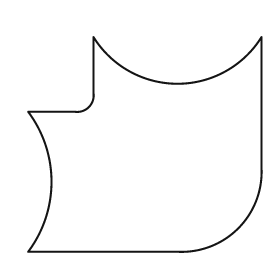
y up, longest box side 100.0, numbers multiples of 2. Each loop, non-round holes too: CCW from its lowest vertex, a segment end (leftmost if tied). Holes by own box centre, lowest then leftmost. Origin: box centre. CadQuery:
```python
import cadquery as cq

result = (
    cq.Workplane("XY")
    .moveTo(-50.0, -46.0)
    .lineTo(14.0, -46.0)
    .threePointArc((40.0, -36.0), (50.0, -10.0))
    .lineTo(50.0, 46.0)
    .threePointArc((14.0, 26.0), (-22.0, 46.0))
    .lineTo(-22.0, 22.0)
    .threePointArc((-24.0, 16.0), (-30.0, 14.0))
    .lineTo(-50.0, 14.0)
    .threePointArc((-40.0, -16.0), (-50.0, -46.0))
    .close()
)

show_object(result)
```